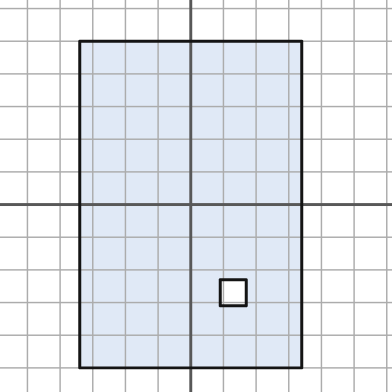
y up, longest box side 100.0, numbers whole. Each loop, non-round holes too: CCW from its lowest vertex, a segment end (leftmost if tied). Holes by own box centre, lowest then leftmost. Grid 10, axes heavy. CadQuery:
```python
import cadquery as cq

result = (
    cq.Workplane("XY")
    .moveTo(-34.0, -50.0)
    .lineTo(34.0, -50.0)
    .lineTo(34.0, 50.0)
    .lineTo(-34.0, 50.0)
    .close()
    .moveTo(9.0, -31.0)
    .lineTo(17.0, -31.0)
    .lineTo(17.0, -23.0)
    .lineTo(9.0, -23.0)
    .close()
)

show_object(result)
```